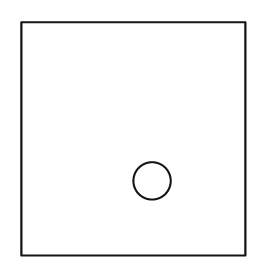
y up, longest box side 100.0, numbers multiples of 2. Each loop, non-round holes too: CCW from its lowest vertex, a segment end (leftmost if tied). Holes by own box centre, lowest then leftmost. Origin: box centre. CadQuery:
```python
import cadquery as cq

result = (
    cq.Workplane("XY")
    .moveTo(-48.0, -50.0)
    .lineTo(48.0, -50.0)
    .lineTo(48.0, 50.0)
    .lineTo(-48.0, 50.0)
    .close()
    .moveTo(8.0, -18.0)
    .circle(8.0)
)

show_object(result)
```